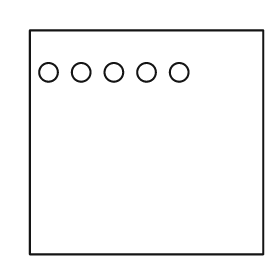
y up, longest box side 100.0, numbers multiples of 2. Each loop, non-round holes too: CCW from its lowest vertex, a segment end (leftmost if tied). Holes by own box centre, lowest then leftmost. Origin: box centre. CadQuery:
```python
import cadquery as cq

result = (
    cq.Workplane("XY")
    .moveTo(-50.0, -48.0)
    .lineTo(50.0, -48.0)
    .lineTo(50.0, 48.0)
    .lineTo(-50.0, 48.0)
    .close()
    .moveTo(-42.0, 30.0)
    .circle(4.0)
    .moveTo(-28.0, 30.0)
    .circle(4.0)
    .moveTo(-14.0, 30.0)
    .circle(4.0)
    .moveTo(0.0, 30.0)
    .circle(4.0)
    .moveTo(14.0, 30.0)
    .circle(4.0)
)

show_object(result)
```